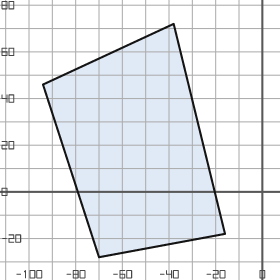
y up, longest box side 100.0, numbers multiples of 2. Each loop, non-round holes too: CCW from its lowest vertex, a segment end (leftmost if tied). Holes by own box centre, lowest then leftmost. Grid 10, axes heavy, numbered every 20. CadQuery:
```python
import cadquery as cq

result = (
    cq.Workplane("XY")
    .moveTo(-70.0, -28.0)
    .lineTo(-16.0, -18.0)
    .lineTo(-38.0, 72.0)
    .lineTo(-94.0, 46.0)
    .close()
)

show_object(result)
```